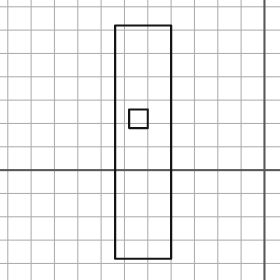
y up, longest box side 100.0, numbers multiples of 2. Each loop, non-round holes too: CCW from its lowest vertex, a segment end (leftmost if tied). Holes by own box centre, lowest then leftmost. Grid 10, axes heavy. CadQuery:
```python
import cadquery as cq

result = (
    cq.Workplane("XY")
    .moveTo(-64.0, -38.0)
    .lineTo(-40.0, -38.0)
    .lineTo(-40.0, 62.0)
    .lineTo(-64.0, 62.0)
    .close()
    .moveTo(-58.0, 18.0)
    .lineTo(-50.0, 18.0)
    .lineTo(-50.0, 26.0)
    .lineTo(-58.0, 26.0)
    .close()
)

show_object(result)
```